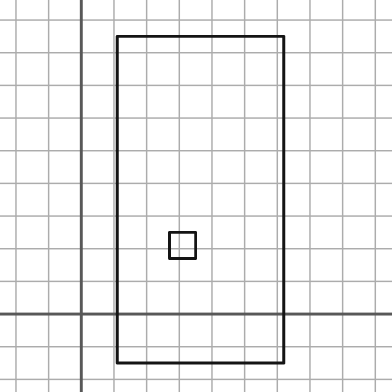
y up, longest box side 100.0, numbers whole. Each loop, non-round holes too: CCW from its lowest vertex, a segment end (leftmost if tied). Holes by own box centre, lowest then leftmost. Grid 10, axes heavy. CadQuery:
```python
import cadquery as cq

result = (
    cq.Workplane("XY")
    .moveTo(11.0, -15.0)
    .lineTo(62.0, -15.0)
    .lineTo(62.0, 85.0)
    .lineTo(11.0, 85.0)
    .close()
    .moveTo(27.0, 17.0)
    .lineTo(35.0, 17.0)
    .lineTo(35.0, 25.0)
    .lineTo(27.0, 25.0)
    .close()
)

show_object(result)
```